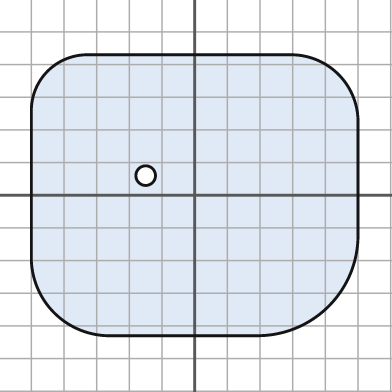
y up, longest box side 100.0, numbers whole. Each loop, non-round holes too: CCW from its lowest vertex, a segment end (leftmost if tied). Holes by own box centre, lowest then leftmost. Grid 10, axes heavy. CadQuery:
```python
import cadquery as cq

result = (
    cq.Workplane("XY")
    .moveTo(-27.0, -43.0)
    .lineTo(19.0, -43.0)
    .threePointArc((41.0, -34.0), (50.0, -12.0))
    .lineTo(50.0, 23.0)
    .threePointArc((44.0, 37.0), (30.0, 43.0))
    .lineTo(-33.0, 43.0)
    .threePointArc((-45.0, 38.0), (-50.0, 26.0))
    .lineTo(-50.0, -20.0)
    .threePointArc((-43.0, -36.0), (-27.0, -43.0))
    .close()
    .moveTo(-15.0, 6.0)
    .circle(3.0)
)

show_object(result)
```